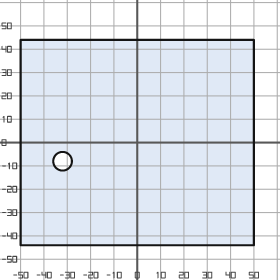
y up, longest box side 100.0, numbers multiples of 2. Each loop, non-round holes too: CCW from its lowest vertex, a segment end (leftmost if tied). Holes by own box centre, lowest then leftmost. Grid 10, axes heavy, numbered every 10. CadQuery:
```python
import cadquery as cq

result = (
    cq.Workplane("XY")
    .moveTo(-50.0, -44.0)
    .lineTo(50.0, -44.0)
    .lineTo(50.0, 44.0)
    .lineTo(-50.0, 44.0)
    .close()
    .moveTo(-32.0, -8.0)
    .circle(4.0)
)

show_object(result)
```